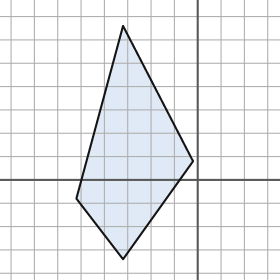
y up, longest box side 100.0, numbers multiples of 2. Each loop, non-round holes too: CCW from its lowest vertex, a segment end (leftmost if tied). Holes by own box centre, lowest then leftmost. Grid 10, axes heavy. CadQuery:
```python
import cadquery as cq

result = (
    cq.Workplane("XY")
    .moveTo(-32.0, -34.0)
    .lineTo(-2.0, 8.0)
    .lineTo(-32.0, 66.0)
    .lineTo(-52.0, -8.0)
    .close()
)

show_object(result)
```